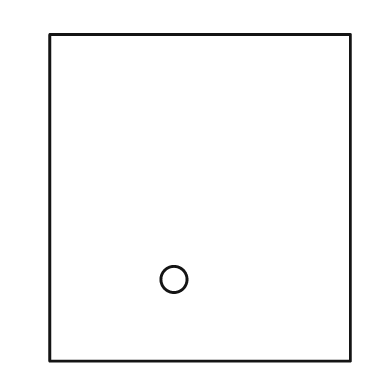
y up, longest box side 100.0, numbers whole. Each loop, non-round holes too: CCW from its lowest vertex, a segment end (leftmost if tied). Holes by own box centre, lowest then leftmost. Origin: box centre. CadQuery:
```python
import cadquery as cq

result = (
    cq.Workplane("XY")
    .moveTo(-46.0, -50.0)
    .lineTo(46.0, -50.0)
    .lineTo(46.0, 50.0)
    .lineTo(-46.0, 50.0)
    .close()
    .moveTo(-8.0, -25.0)
    .circle(4.0)
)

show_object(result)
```